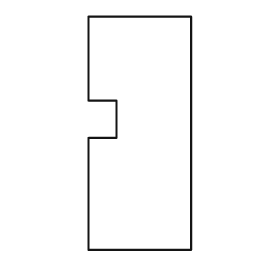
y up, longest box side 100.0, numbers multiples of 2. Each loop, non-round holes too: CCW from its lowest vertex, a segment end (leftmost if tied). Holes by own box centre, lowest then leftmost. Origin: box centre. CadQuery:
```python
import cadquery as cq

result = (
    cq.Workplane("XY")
    .moveTo(-22.0, -50.0)
    .lineTo(22.0, -50.0)
    .lineTo(22.0, 50.0)
    .lineTo(-22.0, 50.0)
    .lineTo(-22.0, 14.0)
    .lineTo(-10.0, 14.0)
    .lineTo(-10.0, -2.0)
    .lineTo(-22.0, -2.0)
    .close()
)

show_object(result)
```